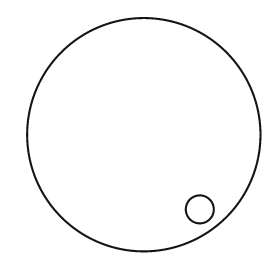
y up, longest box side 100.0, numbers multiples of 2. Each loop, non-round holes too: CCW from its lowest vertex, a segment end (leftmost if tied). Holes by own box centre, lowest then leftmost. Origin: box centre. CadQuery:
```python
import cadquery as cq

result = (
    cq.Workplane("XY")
    .moveTo(0.0, 0.0)
    .circle(50.0)
    .moveTo(24.0, -32.0)
    .circle(6.0)
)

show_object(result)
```